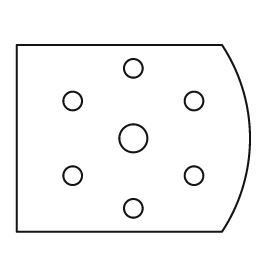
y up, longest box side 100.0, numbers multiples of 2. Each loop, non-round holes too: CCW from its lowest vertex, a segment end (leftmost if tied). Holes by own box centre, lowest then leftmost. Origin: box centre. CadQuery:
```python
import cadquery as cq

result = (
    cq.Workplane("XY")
    .moveTo(-50.0, -40.0)
    .lineTo(38.0, -40.0)
    .threePointArc((50.0, 0.0), (38.0, 40.0))
    .lineTo(-50.0, 40.0)
    .close()
    .moveTo(0.0, -30.0)
    .circle(4.0)
    .moveTo(-26.0, -16.0)
    .circle(4.0)
    .moveTo(26.0, -16.0)
    .circle(4.0)
    .moveTo(0.0, 0.0)
    .circle(6.0)
    .moveTo(-26.0, 16.0)
    .circle(4.0)
    .moveTo(26.0, 16.0)
    .circle(4.0)
    .moveTo(0.0, 30.0)
    .circle(4.0)
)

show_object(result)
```